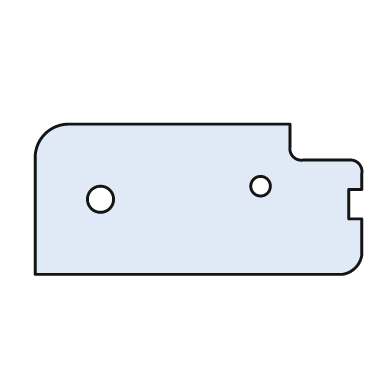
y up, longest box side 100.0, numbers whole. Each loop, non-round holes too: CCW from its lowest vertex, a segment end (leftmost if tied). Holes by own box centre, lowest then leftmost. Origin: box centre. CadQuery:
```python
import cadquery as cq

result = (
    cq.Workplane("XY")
    .moveTo(-50.0, -23.0)
    .lineTo(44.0, -23.0)
    .threePointArc((48.0, -21.0), (50.0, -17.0))
    .lineTo(50.0, -6.0)
    .lineTo(46.0, -6.0)
    .lineTo(46.0, 3.0)
    .lineTo(50.0, 3.0)
    .lineTo(50.0, 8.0)
    .threePointArc((49.0, 11.0), (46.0, 12.0))
    .lineTo(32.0, 12.0)
    .threePointArc((29.0, 13.0), (28.0, 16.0))
    .lineTo(28.0, 23.0)
    .lineTo(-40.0, 23.0)
    .threePointArc((-47.0, 20.0), (-50.0, 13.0))
    .close()
    .moveTo(-30.0, 0.0)
    .circle(4.0)
    .moveTo(19.0, 4.0)
    .circle(3.0)
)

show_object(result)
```